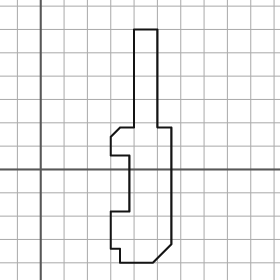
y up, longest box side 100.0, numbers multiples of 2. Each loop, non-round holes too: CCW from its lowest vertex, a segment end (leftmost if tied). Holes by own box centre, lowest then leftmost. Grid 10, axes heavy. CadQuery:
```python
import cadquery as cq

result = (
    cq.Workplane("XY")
    .moveTo(34.0, -40.0)
    .lineTo(48.0, -40.0)
    .lineTo(56.0, -32.0)
    .lineTo(56.0, 18.0)
    .lineTo(50.0, 18.0)
    .lineTo(50.0, 60.0)
    .lineTo(40.0, 60.0)
    .lineTo(40.0, 18.0)
    .lineTo(34.0, 18.0)
    .lineTo(30.0, 14.0)
    .lineTo(30.0, 6.0)
    .lineTo(38.0, 6.0)
    .lineTo(38.0, -18.0)
    .lineTo(30.0, -18.0)
    .lineTo(30.0, -34.0)
    .lineTo(34.0, -34.0)
    .close()
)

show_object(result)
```